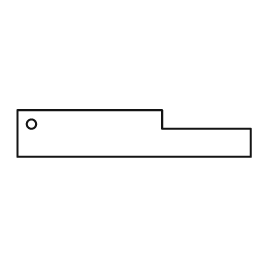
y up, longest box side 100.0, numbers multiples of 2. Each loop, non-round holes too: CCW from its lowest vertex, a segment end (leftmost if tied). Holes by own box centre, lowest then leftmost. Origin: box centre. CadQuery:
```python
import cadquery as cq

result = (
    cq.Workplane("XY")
    .moveTo(-50.0, -10.0)
    .lineTo(50.0, -10.0)
    .lineTo(50.0, 2.0)
    .lineTo(12.0, 2.0)
    .lineTo(12.0, 10.0)
    .lineTo(-50.0, 10.0)
    .close()
    .moveTo(-44.0, 4.0)
    .circle(2.0)
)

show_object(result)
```